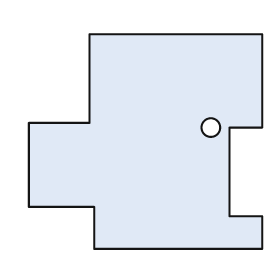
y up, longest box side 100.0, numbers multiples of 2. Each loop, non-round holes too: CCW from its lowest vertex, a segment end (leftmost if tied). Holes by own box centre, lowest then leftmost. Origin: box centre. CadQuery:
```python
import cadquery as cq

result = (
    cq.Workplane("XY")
    .moveTo(-22.0, -46.0)
    .lineTo(50.0, -46.0)
    .lineTo(50.0, -32.0)
    .lineTo(36.0, -32.0)
    .lineTo(36.0, 6.0)
    .lineTo(50.0, 6.0)
    .lineTo(50.0, 46.0)
    .lineTo(-24.0, 46.0)
    .lineTo(-24.0, 8.0)
    .lineTo(-50.0, 8.0)
    .lineTo(-50.0, -28.0)
    .lineTo(-22.0, -28.0)
    .close()
    .moveTo(28.0, 6.0)
    .circle(4.0)
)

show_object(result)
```